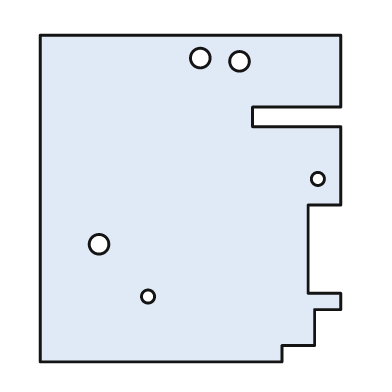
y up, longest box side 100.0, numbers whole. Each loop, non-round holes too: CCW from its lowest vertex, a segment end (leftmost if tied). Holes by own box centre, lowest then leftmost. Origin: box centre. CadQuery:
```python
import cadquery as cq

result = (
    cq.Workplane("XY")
    .moveTo(-46.0, -50.0)
    .lineTo(28.0, -50.0)
    .lineTo(28.0, -45.0)
    .lineTo(38.0, -45.0)
    .lineTo(38.0, -34.0)
    .lineTo(46.0, -34.0)
    .lineTo(46.0, -29.0)
    .lineTo(36.0, -29.0)
    .lineTo(36.0, -2.0)
    .lineTo(46.0, -2.0)
    .lineTo(46.0, 22.0)
    .lineTo(19.0, 22.0)
    .lineTo(19.0, 28.0)
    .lineTo(46.0, 28.0)
    .lineTo(46.0, 50.0)
    .lineTo(-46.0, 50.0)
    .close()
    .moveTo(-13.0, -30.0)
    .circle(2.0)
    .moveTo(-28.0, -14.0)
    .circle(3.0)
    .moveTo(39.0, 6.0)
    .circle(2.0)
    .moveTo(15.0, 42.0)
    .circle(3.0)
    .moveTo(3.0, 43.0)
    .circle(3.0)
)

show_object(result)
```